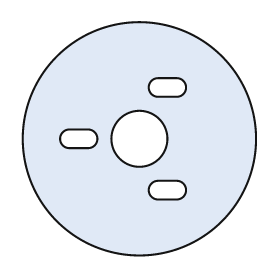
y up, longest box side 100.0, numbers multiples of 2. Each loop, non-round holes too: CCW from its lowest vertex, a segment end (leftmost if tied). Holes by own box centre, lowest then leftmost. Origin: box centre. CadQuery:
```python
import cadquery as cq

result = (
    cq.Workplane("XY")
    .moveTo(0.0, 0.0)
    .circle(50.0)
    .moveTo(8.0, -26.0)
    .lineTo(16.0, -26.0)
    .threePointArc((20.0, -22.0), (16.0, -18.0))
    .lineTo(8.0, -18.0)
    .threePointArc((4.0, -22.0), (8.0, -26.0))
    .close()
    .moveTo(-30.0, -4.0)
    .lineTo(-22.0, -4.0)
    .threePointArc((-18.0, 0.0), (-22.0, 4.0))
    .lineTo(-30.0, 4.0)
    .threePointArc((-34.0, 0.0), (-30.0, -4.0))
    .close()
    .moveTo(0.0, 0.0)
    .circle(12.0)
    .moveTo(8.0, 18.0)
    .lineTo(16.0, 18.0)
    .threePointArc((20.0, 22.0), (16.0, 26.0))
    .lineTo(8.0, 26.0)
    .threePointArc((4.0, 22.0), (8.0, 18.0))
    .close()
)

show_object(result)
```